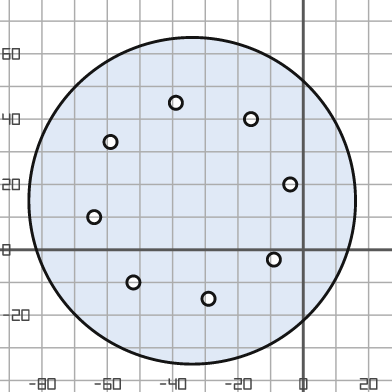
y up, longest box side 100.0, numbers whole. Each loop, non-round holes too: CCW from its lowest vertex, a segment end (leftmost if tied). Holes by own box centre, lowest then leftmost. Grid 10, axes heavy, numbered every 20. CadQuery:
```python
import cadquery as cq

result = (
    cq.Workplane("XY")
    .moveTo(-34.0, 15.0)
    .circle(50.0)
    .moveTo(-29.0, -15.0)
    .circle(2.0)
    .moveTo(-52.0, -10.0)
    .circle(2.0)
    .moveTo(-9.0, -3.0)
    .circle(2.0)
    .moveTo(-64.0, 10.0)
    .circle(2.0)
    .moveTo(-4.0, 20.0)
    .circle(2.0)
    .moveTo(-59.0, 33.0)
    .circle(2.0)
    .moveTo(-16.0, 40.0)
    .circle(2.0)
    .moveTo(-39.0, 45.0)
    .circle(2.0)
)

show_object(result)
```